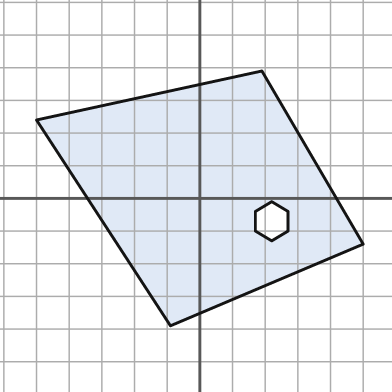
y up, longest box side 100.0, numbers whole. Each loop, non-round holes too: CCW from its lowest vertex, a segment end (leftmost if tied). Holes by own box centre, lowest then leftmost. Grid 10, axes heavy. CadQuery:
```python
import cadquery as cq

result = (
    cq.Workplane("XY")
    .moveTo(-9.0, -39.0)
    .lineTo(50.0, -14.0)
    .lineTo(19.0, 39.0)
    .lineTo(-50.0, 24.0)
    .close()
    .moveTo(22.0, -13.0)
    .lineTo(27.0, -10.0)
    .lineTo(27.0, -4.0)
    .lineTo(22.0, -1.0)
    .lineTo(17.0, -4.0)
    .lineTo(17.0, -10.0)
    .close()
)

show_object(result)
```